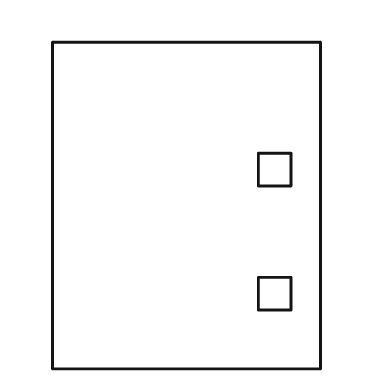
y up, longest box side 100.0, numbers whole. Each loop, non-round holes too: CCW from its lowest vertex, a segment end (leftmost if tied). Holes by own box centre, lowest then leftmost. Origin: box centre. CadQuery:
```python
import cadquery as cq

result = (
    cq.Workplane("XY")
    .moveTo(-41.0, -50.0)
    .lineTo(41.0, -50.0)
    .lineTo(41.0, 50.0)
    .lineTo(-41.0, 50.0)
    .close()
    .moveTo(22.0, -32.0)
    .lineTo(32.0, -32.0)
    .lineTo(32.0, -22.0)
    .lineTo(22.0, -22.0)
    .close()
    .moveTo(22.0, 6.0)
    .lineTo(32.0, 6.0)
    .lineTo(32.0, 16.0)
    .lineTo(22.0, 16.0)
    .close()
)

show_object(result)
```